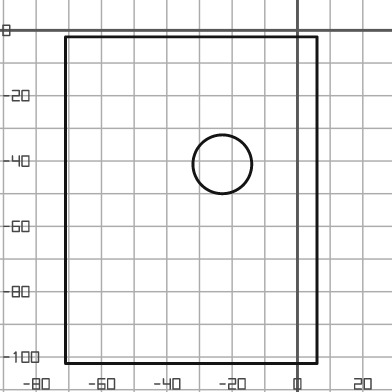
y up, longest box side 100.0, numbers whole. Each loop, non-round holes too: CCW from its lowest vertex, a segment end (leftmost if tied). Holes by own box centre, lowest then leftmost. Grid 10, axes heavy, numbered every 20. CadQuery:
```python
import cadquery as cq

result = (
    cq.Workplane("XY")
    .moveTo(-71.0, -102.0)
    .lineTo(6.0, -102.0)
    .lineTo(6.0, -2.0)
    .lineTo(-71.0, -2.0)
    .close()
    .moveTo(-23.0, -41.0)
    .circle(9.0)
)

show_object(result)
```